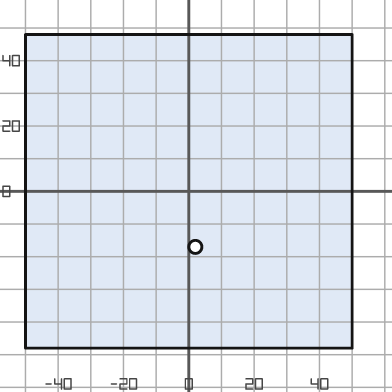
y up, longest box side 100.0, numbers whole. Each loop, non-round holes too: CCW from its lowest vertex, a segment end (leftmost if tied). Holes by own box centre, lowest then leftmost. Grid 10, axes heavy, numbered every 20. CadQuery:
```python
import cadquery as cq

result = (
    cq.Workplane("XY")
    .moveTo(-50.0, -48.0)
    .lineTo(50.0, -48.0)
    .lineTo(50.0, 48.0)
    .lineTo(-50.0, 48.0)
    .close()
    .moveTo(2.0, -17.0)
    .circle(2.0)
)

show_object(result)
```